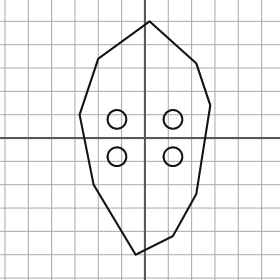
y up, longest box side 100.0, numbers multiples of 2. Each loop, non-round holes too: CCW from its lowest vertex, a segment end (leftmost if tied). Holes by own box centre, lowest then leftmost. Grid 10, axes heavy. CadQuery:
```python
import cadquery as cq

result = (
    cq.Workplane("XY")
    .moveTo(-4.0, -50.0)
    .lineTo(12.0, -42.0)
    .lineTo(22.0, -24.0)
    .lineTo(28.0, 14.0)
    .lineTo(22.0, 32.0)
    .lineTo(2.0, 50.0)
    .lineTo(-20.0, 34.0)
    .lineTo(-28.0, 10.0)
    .lineTo(-22.0, -20.0)
    .close()
    .moveTo(-12.0, -8.0)
    .circle(4.0)
    .moveTo(12.0, -8.0)
    .circle(4.0)
    .moveTo(-12.0, 8.0)
    .circle(4.0)
    .moveTo(12.0, 8.0)
    .circle(4.0)
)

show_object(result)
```